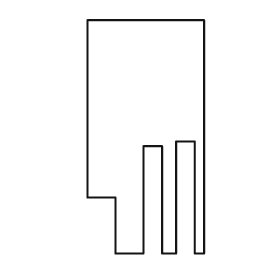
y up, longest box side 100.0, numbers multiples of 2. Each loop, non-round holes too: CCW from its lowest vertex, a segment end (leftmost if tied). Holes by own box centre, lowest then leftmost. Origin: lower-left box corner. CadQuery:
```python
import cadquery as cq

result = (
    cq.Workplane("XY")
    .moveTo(12.0, 0.0)
    .lineTo(24.0, 0.0)
    .lineTo(24.0, 46.0)
    .lineTo(32.0, 46.0)
    .lineTo(32.0, 0.0)
    .lineTo(38.0, 0.0)
    .lineTo(38.0, 48.0)
    .lineTo(46.0, 48.0)
    .lineTo(46.0, 0.0)
    .lineTo(50.0, 0.0)
    .lineTo(50.0, 100.0)
    .lineTo(0.0, 100.0)
    .lineTo(0.0, 24.0)
    .lineTo(12.0, 24.0)
    .close()
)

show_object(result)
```